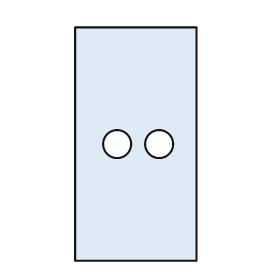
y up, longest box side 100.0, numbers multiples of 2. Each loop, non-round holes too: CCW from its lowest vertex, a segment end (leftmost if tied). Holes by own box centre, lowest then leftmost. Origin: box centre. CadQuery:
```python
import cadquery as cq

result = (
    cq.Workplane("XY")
    .moveTo(-26.0, -50.0)
    .lineTo(26.0, -50.0)
    .lineTo(26.0, 50.0)
    .lineTo(-26.0, 50.0)
    .close()
    .moveTo(-8.0, 0.0)
    .circle(6.0)
    .moveTo(10.0, 0.0)
    .circle(6.0)
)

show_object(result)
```